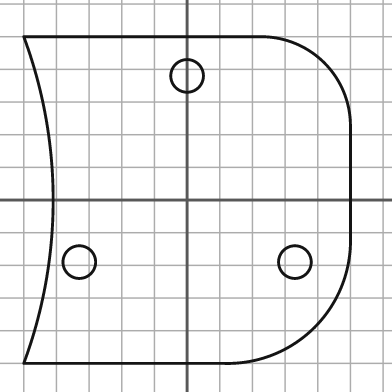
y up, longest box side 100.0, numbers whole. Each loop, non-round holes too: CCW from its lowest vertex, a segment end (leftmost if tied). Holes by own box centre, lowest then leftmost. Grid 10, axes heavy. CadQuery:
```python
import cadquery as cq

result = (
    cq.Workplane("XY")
    .moveTo(-50.0, -50.0)
    .lineTo(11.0, -50.0)
    .threePointArc((39.0, -39.0), (50.0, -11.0))
    .lineTo(50.0, 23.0)
    .threePointArc((42.0, 42.0), (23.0, 50.0))
    .lineTo(-50.0, 50.0)
    .threePointArc((-41.0, 0.0), (-50.0, -50.0))
    .close()
    .moveTo(-33.0, -19.0)
    .circle(5.0)
    .moveTo(33.0, -19.0)
    .circle(5.0)
    .moveTo(0.0, 38.0)
    .circle(5.0)
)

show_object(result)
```